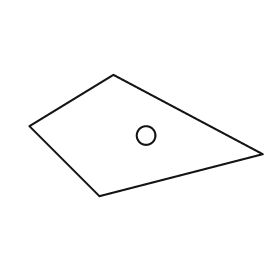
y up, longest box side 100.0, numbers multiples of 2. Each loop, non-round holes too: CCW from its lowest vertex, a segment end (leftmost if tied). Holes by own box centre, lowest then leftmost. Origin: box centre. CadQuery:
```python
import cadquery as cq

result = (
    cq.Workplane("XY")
    .moveTo(-20.0, -26.0)
    .lineTo(50.0, -8.0)
    .lineTo(-14.0, 26.0)
    .lineTo(-50.0, 4.0)
    .close()
    .moveTo(0.0, 0.0)
    .circle(4.0)
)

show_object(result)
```